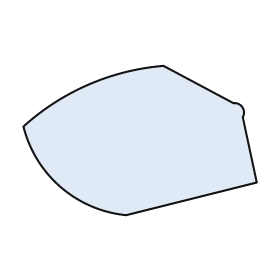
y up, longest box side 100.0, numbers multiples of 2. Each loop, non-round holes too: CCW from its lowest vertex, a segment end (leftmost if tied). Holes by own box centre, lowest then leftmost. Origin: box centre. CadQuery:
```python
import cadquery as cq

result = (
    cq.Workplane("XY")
    .moveTo(-6.0, -32.0)
    .lineTo(50.0, -18.0)
    .lineTo(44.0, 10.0)
    .threePointArc((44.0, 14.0), (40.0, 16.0))
    .lineTo(10.0, 32.0)
    .threePointArc((-22.0, 24.0), (-50.0, 6.0))
    .threePointArc((-34.0, -20.0), (-6.0, -32.0))
    .close()
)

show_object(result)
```